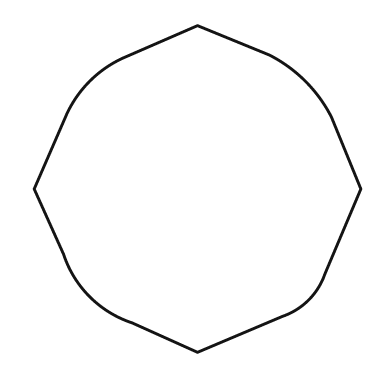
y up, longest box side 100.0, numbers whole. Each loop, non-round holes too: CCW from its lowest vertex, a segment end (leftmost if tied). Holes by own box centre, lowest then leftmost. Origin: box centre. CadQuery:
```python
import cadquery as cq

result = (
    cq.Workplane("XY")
    .moveTo(0.0, -50.0)
    .lineTo(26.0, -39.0)
    .threePointArc((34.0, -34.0), (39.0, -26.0))
    .lineTo(50.0, 0.0)
    .lineTo(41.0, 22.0)
    .threePointArc((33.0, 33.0), (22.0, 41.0))
    .lineTo(0.0, 50.0)
    .lineTo(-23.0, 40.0)
    .threePointArc((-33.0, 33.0), (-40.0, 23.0))
    .lineTo(-50.0, 0.0)
    .lineTo(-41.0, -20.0)
    .threePointArc((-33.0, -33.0), (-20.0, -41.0))
    .close()
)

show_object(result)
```